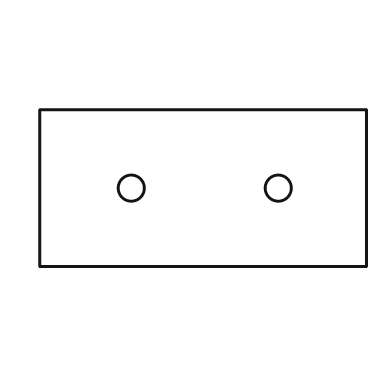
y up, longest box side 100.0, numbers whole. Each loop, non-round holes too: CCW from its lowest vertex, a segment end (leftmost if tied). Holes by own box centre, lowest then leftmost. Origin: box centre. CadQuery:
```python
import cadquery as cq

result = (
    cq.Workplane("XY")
    .moveTo(-50.0, -24.0)
    .lineTo(50.0, -24.0)
    .lineTo(50.0, 24.0)
    .lineTo(-50.0, 24.0)
    .close()
    .moveTo(-22.0, 0.0)
    .circle(4.0)
    .moveTo(23.0, 0.0)
    .circle(4.0)
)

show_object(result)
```